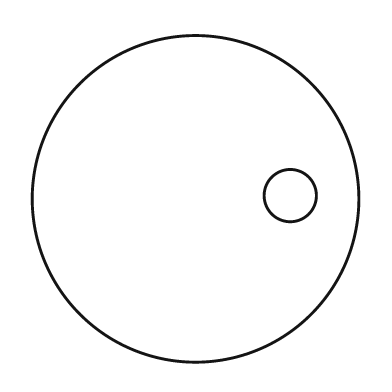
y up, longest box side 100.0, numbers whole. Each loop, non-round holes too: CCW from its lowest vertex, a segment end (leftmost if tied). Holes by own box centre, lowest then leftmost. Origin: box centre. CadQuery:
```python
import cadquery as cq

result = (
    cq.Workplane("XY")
    .moveTo(0.0, 0.0)
    .circle(50.0)
    .moveTo(29.0, 1.0)
    .circle(8.0)
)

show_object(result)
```